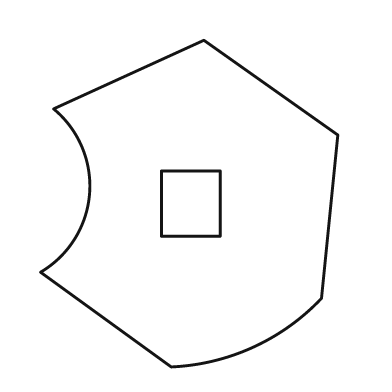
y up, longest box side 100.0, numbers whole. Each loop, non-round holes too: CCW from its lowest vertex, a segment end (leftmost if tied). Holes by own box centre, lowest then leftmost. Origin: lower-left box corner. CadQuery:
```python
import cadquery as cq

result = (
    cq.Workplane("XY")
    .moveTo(40.0, 0.0)
    .threePointArc((65.0, 6.0), (86.0, 21.0))
    .lineTo(91.0, 71.0)
    .lineTo(50.0, 100.0)
    .lineTo(4.0, 79.0)
    .threePointArc((15.0, 53.0), (0.0, 29.0))
    .close()
    .moveTo(37.0, 40.0)
    .lineTo(55.0, 40.0)
    .lineTo(55.0, 60.0)
    .lineTo(37.0, 60.0)
    .close()
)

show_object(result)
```